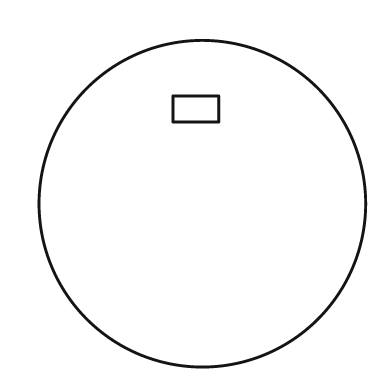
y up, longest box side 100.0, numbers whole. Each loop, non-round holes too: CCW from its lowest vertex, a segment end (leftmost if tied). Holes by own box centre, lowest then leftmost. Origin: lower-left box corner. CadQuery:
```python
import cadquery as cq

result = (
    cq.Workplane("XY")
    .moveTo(50.0, 50.0)
    .circle(50.0)
    .moveTo(41.0, 75.0)
    .lineTo(55.0, 75.0)
    .lineTo(55.0, 83.0)
    .lineTo(41.0, 83.0)
    .close()
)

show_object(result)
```